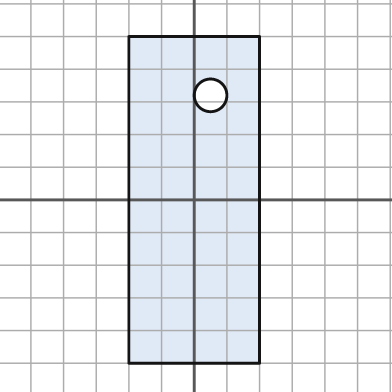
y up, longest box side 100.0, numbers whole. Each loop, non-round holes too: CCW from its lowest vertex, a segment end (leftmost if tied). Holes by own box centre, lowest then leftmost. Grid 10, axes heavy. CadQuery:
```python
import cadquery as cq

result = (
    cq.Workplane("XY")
    .moveTo(-20.0, -50.0)
    .lineTo(20.0, -50.0)
    .lineTo(20.0, 50.0)
    .lineTo(-20.0, 50.0)
    .close()
    .moveTo(5.0, 32.0)
    .circle(5.0)
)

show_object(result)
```